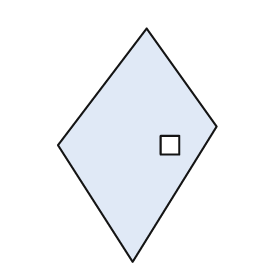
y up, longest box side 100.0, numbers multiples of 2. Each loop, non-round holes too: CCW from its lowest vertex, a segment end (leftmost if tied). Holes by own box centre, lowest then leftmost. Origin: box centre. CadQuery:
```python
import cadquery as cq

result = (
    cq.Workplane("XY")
    .moveTo(-2.0, -50.0)
    .lineTo(34.0, 8.0)
    .lineTo(4.0, 50.0)
    .lineTo(-34.0, 0.0)
    .close()
    .moveTo(10.0, -4.0)
    .lineTo(18.0, -4.0)
    .lineTo(18.0, 4.0)
    .lineTo(10.0, 4.0)
    .close()
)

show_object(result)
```